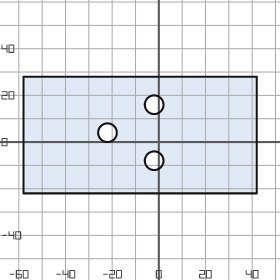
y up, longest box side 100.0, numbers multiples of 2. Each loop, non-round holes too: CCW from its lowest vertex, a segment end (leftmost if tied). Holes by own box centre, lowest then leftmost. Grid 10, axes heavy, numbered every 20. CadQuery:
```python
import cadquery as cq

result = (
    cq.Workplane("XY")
    .moveTo(-58.0, -22.0)
    .lineTo(42.0, -22.0)
    .lineTo(42.0, 28.0)
    .lineTo(-58.0, 28.0)
    .close()
    .moveTo(-2.0, -8.0)
    .circle(4.0)
    .moveTo(-22.0, 4.0)
    .circle(4.0)
    .moveTo(-2.0, 16.0)
    .circle(4.0)
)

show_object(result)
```